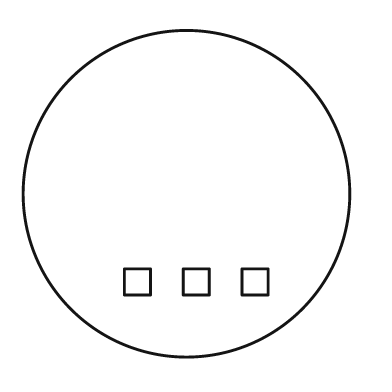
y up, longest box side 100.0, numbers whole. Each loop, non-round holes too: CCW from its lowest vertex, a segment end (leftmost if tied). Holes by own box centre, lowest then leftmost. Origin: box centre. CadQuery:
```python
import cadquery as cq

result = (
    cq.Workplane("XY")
    .moveTo(0.0, 0.0)
    .circle(50.0)
    .moveTo(-19.0, -31.0)
    .lineTo(-11.0, -31.0)
    .lineTo(-11.0, -23.0)
    .lineTo(-19.0, -23.0)
    .close()
    .moveTo(-1.0, -31.0)
    .lineTo(7.0, -31.0)
    .lineTo(7.0, -23.0)
    .lineTo(-1.0, -23.0)
    .close()
    .moveTo(17.0, -31.0)
    .lineTo(25.0, -31.0)
    .lineTo(25.0, -23.0)
    .lineTo(17.0, -23.0)
    .close()
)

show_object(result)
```